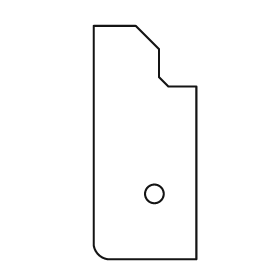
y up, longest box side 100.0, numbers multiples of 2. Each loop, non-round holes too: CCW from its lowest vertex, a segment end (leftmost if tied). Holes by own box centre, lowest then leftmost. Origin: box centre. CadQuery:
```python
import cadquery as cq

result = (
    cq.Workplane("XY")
    .moveTo(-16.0, -50.0)
    .lineTo(22.0, -50.0)
    .lineTo(22.0, 24.0)
    .lineTo(10.0, 24.0)
    .lineTo(6.0, 28.0)
    .lineTo(6.0, 40.0)
    .lineTo(-4.0, 50.0)
    .lineTo(-22.0, 50.0)
    .lineTo(-22.0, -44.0)
    .threePointArc((-20.0, -48.0), (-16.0, -50.0))
    .close()
    .moveTo(4.0, -22.0)
    .circle(4.0)
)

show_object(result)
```